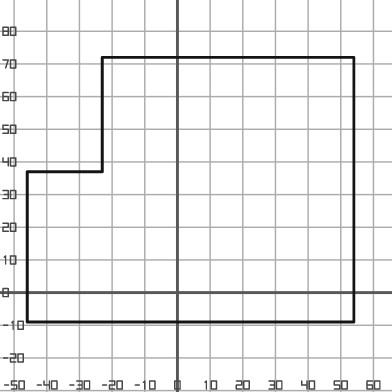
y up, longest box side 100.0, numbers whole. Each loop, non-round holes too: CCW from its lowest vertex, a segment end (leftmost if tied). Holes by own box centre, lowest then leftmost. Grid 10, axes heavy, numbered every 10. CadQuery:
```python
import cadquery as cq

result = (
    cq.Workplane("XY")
    .moveTo(-46.0, -9.0)
    .lineTo(54.0, -9.0)
    .lineTo(54.0, 72.0)
    .lineTo(-23.0, 72.0)
    .lineTo(-23.0, 37.0)
    .lineTo(-46.0, 37.0)
    .close()
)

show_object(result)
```